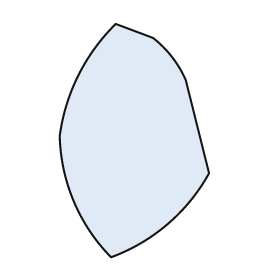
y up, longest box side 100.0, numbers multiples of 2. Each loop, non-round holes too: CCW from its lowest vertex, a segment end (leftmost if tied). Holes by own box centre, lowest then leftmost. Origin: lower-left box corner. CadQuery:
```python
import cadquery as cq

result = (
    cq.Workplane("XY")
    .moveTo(22.0, 0.0)
    .threePointArc((46.0, 14.0), (64.0, 36.0))
    .lineTo(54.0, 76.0)
    .threePointArc((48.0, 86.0), (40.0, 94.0))
    .lineTo(24.0, 100.0)
    .threePointArc((8.0, 78.0), (0.0, 52.0))
    .threePointArc((6.0, 24.0), (22.0, 0.0))
    .close()
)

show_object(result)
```